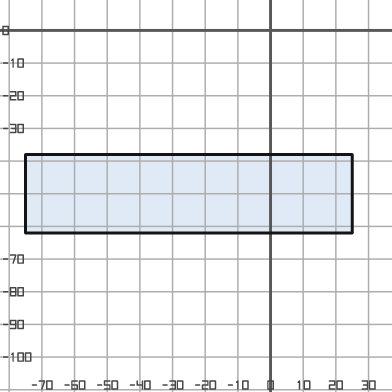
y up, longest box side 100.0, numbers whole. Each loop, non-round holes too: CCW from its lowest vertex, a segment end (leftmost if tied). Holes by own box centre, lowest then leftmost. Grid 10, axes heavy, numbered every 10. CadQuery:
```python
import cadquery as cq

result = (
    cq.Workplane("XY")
    .moveTo(-75.0, -62.0)
    .lineTo(25.0, -62.0)
    .lineTo(25.0, -38.0)
    .lineTo(-75.0, -38.0)
    .close()
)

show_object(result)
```